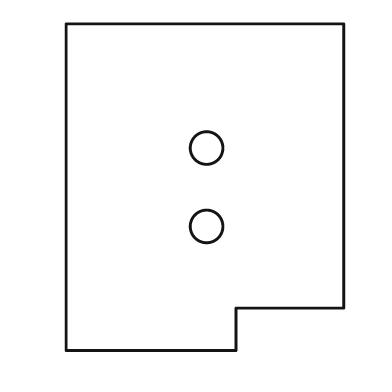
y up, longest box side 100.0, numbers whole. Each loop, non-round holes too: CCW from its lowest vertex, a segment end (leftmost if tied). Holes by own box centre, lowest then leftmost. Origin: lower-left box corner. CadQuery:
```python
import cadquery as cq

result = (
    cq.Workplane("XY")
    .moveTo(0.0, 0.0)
    .lineTo(52.0, 0.0)
    .lineTo(52.0, 13.0)
    .lineTo(85.0, 13.0)
    .lineTo(85.0, 100.0)
    .lineTo(0.0, 100.0)
    .close()
    .moveTo(43.0, 38.0)
    .circle(5.0)
    .moveTo(43.0, 62.0)
    .circle(5.0)
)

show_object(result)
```